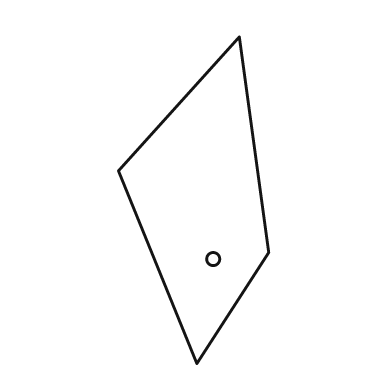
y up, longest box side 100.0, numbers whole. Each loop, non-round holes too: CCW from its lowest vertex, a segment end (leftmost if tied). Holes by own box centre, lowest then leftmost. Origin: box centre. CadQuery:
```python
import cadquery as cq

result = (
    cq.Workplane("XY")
    .moveTo(1.0, -50.0)
    .lineTo(23.0, -16.0)
    .lineTo(14.0, 50.0)
    .lineTo(-23.0, 9.0)
    .close()
    .moveTo(6.0, -18.0)
    .circle(2.0)
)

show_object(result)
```